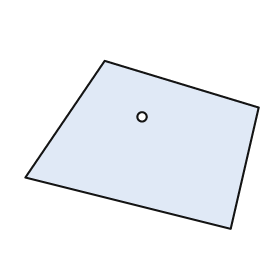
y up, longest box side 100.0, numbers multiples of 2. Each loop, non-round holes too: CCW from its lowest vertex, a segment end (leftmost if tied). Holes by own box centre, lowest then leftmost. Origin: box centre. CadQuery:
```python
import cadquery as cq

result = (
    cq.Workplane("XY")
    .moveTo(38.0, -36.0)
    .lineTo(50.0, 16.0)
    .lineTo(-16.0, 36.0)
    .lineTo(-50.0, -14.0)
    .close()
    .moveTo(0.0, 12.0)
    .circle(2.0)
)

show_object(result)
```